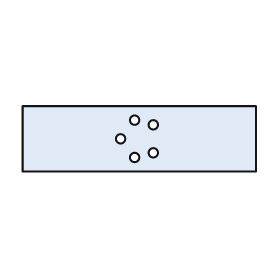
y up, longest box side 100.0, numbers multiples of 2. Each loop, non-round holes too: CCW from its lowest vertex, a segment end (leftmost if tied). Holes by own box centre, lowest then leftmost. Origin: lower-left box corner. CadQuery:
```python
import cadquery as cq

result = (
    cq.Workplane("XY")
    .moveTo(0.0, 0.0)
    .lineTo(100.0, 0.0)
    .lineTo(100.0, 28.0)
    .lineTo(0.0, 28.0)
    .close()
    .moveTo(48.0, 6.0)
    .circle(2.0)
    .moveTo(56.0, 8.0)
    .circle(2.0)
    .moveTo(42.0, 14.0)
    .circle(2.0)
    .moveTo(56.0, 20.0)
    .circle(2.0)
    .moveTo(48.0, 22.0)
    .circle(2.0)
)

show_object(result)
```